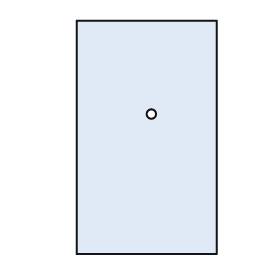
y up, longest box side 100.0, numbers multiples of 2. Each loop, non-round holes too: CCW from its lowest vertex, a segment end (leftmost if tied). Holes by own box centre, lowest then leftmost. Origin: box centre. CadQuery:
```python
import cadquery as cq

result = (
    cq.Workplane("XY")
    .moveTo(-30.0, -50.0)
    .lineTo(30.0, -50.0)
    .lineTo(30.0, 50.0)
    .lineTo(-30.0, 50.0)
    .close()
    .moveTo(2.0, 10.0)
    .circle(2.0)
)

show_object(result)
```